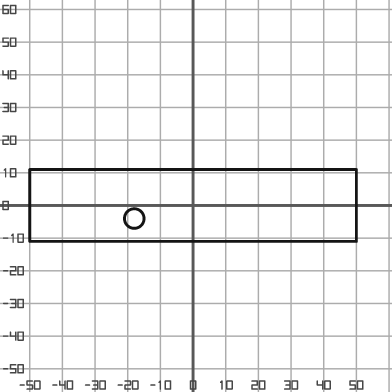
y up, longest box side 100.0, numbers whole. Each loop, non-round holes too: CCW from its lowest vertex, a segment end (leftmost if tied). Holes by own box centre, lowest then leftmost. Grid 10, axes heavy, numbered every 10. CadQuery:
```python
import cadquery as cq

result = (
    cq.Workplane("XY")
    .moveTo(-50.0, -11.0)
    .lineTo(50.0, -11.0)
    .lineTo(50.0, 11.0)
    .lineTo(-50.0, 11.0)
    .close()
    .moveTo(-18.0, -4.0)
    .circle(3.0)
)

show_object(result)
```